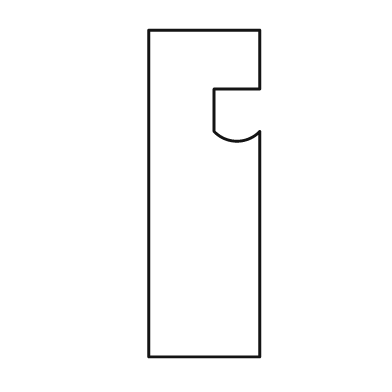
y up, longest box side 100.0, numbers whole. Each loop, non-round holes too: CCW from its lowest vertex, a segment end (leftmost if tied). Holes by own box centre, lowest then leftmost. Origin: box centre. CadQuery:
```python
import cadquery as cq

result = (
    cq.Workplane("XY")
    .moveTo(-17.0, -50.0)
    .lineTo(17.0, -50.0)
    .lineTo(17.0, 19.0)
    .threePointArc((10.0, 16.0), (3.0, 19.0))
    .lineTo(3.0, 32.0)
    .lineTo(17.0, 32.0)
    .lineTo(17.0, 50.0)
    .lineTo(-17.0, 50.0)
    .close()
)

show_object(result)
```